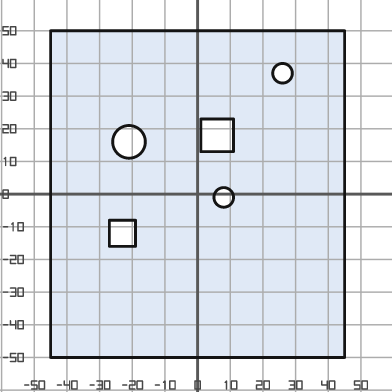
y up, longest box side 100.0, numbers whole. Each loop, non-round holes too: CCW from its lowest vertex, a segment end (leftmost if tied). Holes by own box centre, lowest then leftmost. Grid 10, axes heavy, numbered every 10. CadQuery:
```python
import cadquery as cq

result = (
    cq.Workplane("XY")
    .moveTo(-45.0, -50.0)
    .lineTo(45.0, -50.0)
    .lineTo(45.0, 50.0)
    .lineTo(-45.0, 50.0)
    .close()
    .moveTo(-27.0, -16.0)
    .lineTo(-19.0, -16.0)
    .lineTo(-19.0, -8.0)
    .lineTo(-27.0, -8.0)
    .close()
    .moveTo(8.0, -1.0)
    .circle(3.0)
    .moveTo(-21.0, 16.0)
    .circle(5.0)
    .moveTo(1.0, 13.0)
    .lineTo(11.0, 13.0)
    .lineTo(11.0, 23.0)
    .lineTo(1.0, 23.0)
    .close()
    .moveTo(26.0, 37.0)
    .circle(3.0)
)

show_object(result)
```